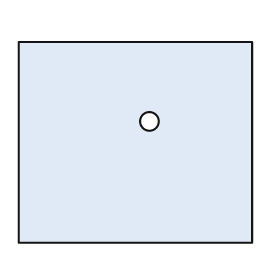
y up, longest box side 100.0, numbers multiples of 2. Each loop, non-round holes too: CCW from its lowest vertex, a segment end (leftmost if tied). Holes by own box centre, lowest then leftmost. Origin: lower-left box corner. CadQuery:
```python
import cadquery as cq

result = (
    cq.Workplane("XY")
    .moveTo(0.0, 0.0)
    .lineTo(100.0, 0.0)
    .lineTo(100.0, 86.0)
    .lineTo(0.0, 86.0)
    .close()
    .moveTo(56.0, 52.0)
    .circle(4.0)
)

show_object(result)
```